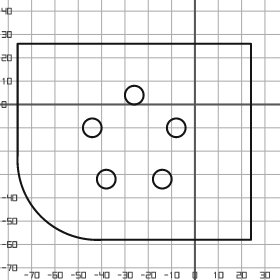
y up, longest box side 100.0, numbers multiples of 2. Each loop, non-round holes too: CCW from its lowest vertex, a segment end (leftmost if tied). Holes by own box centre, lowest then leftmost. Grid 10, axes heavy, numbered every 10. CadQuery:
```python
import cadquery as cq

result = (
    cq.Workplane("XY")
    .moveTo(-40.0, -58.0)
    .lineTo(24.0, -58.0)
    .lineTo(24.0, 26.0)
    .lineTo(-76.0, 26.0)
    .lineTo(-76.0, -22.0)
    .threePointArc((-66.0, -48.0), (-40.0, -58.0))
    .close()
    .moveTo(-38.0, -32.0)
    .circle(4.0)
    .moveTo(-14.0, -32.0)
    .circle(4.0)
    .moveTo(-44.0, -10.0)
    .circle(4.0)
    .moveTo(-8.0, -10.0)
    .circle(4.0)
    .moveTo(-26.0, 4.0)
    .circle(4.0)
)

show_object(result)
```